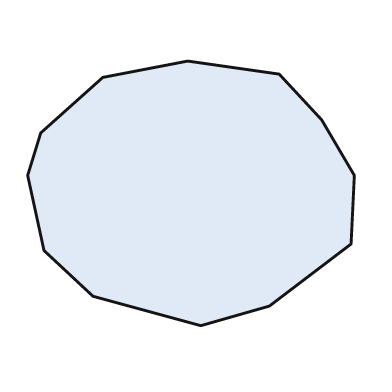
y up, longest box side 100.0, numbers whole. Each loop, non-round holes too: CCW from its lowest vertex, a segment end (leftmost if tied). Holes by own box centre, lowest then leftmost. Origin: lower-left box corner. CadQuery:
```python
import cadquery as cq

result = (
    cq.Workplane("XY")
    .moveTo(53.0, 0.0)
    .lineTo(74.0, 6.0)
    .lineTo(99.0, 25.0)
    .lineTo(100.0, 46.0)
    .lineTo(90.0, 63.0)
    .lineTo(77.0, 77.0)
    .lineTo(49.0, 81.0)
    .lineTo(23.0, 76.0)
    .lineTo(4.0, 59.0)
    .lineTo(0.0, 46.0)
    .lineTo(5.0, 23.0)
    .lineTo(20.0, 9.0)
    .close()
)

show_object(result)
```